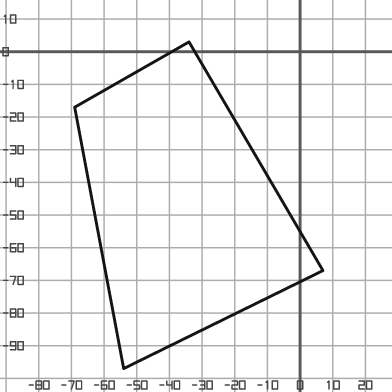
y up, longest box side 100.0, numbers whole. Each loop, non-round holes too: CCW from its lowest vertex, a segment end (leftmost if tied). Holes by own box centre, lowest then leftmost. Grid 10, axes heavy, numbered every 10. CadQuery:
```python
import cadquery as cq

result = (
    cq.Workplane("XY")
    .moveTo(-54.0, -97.0)
    .lineTo(7.0, -67.0)
    .lineTo(-34.0, 3.0)
    .lineTo(-69.0, -17.0)
    .close()
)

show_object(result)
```